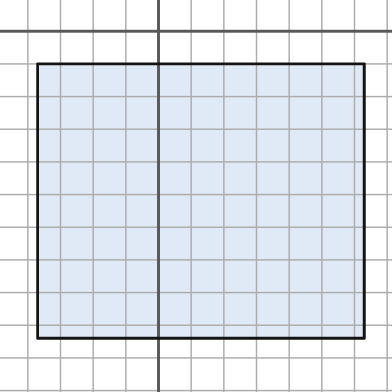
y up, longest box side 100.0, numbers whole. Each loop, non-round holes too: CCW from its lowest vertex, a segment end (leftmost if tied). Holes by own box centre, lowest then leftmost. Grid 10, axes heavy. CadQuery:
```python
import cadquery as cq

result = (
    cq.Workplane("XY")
    .moveTo(-37.0, -94.0)
    .lineTo(63.0, -94.0)
    .lineTo(63.0, -10.0)
    .lineTo(-37.0, -10.0)
    .close()
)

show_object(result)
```